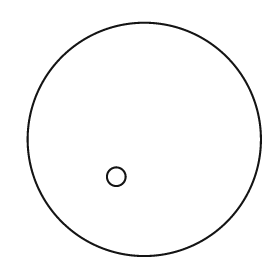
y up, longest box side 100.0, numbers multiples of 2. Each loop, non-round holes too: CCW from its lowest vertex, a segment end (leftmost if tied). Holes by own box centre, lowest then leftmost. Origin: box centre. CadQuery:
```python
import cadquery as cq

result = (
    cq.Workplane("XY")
    .moveTo(0.0, 0.0)
    .circle(50.0)
    .moveTo(-12.0, -16.0)
    .circle(4.0)
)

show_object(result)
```